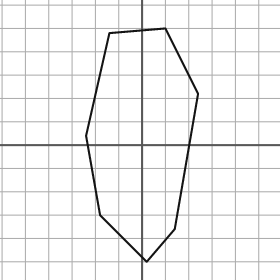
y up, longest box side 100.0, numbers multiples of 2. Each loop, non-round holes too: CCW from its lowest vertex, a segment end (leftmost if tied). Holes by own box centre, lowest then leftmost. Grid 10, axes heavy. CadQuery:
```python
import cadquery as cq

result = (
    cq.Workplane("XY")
    .moveTo(2.0, -50.0)
    .lineTo(14.0, -36.0)
    .lineTo(24.0, 22.0)
    .lineTo(10.0, 50.0)
    .lineTo(-14.0, 48.0)
    .lineTo(-24.0, 4.0)
    .lineTo(-18.0, -30.0)
    .close()
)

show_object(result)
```